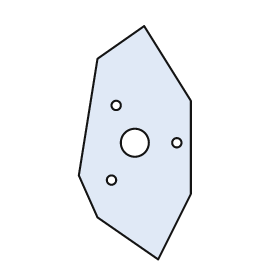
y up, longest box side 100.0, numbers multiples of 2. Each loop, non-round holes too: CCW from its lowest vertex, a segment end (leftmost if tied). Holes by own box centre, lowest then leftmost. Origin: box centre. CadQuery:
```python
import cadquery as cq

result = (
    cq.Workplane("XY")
    .moveTo(10.0, -50.0)
    .lineTo(24.0, -22.0)
    .lineTo(24.0, 18.0)
    .lineTo(4.0, 50.0)
    .lineTo(-16.0, 36.0)
    .lineTo(-24.0, -14.0)
    .lineTo(-16.0, -32.0)
    .close()
    .moveTo(-10.0, -16.0)
    .circle(2.0)
    .moveTo(0.0, 0.0)
    .circle(6.0)
    .moveTo(18.0, 0.0)
    .circle(2.0)
    .moveTo(-8.0, 16.0)
    .circle(2.0)
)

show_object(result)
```